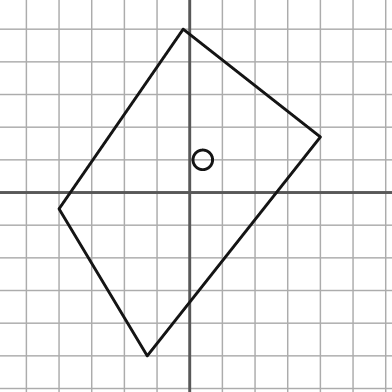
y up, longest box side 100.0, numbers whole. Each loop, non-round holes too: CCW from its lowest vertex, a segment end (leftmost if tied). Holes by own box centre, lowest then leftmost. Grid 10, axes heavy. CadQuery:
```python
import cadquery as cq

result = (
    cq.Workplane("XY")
    .moveTo(-13.0, -50.0)
    .lineTo(40.0, 17.0)
    .lineTo(-2.0, 50.0)
    .lineTo(-40.0, -5.0)
    .close()
    .moveTo(4.0, 10.0)
    .circle(3.0)
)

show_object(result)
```